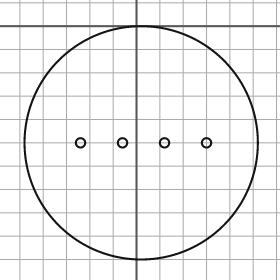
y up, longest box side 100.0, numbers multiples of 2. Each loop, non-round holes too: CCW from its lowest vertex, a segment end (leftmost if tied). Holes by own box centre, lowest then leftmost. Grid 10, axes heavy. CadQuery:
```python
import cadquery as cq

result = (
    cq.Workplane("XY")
    .moveTo(2.0, -50.0)
    .circle(50.0)
    .moveTo(-24.0, -50.0)
    .circle(2.0)
    .moveTo(-6.0, -50.0)
    .circle(2.0)
    .moveTo(12.0, -50.0)
    .circle(2.0)
    .moveTo(30.0, -50.0)
    .circle(2.0)
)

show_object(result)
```